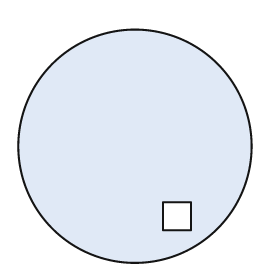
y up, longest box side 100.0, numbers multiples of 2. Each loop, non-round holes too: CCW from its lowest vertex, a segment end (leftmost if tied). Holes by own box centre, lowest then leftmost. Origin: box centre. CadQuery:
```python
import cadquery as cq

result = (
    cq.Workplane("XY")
    .moveTo(0.0, 0.0)
    .circle(50.0)
    .moveTo(12.0, -36.0)
    .lineTo(24.0, -36.0)
    .lineTo(24.0, -24.0)
    .lineTo(12.0, -24.0)
    .close()
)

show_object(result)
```